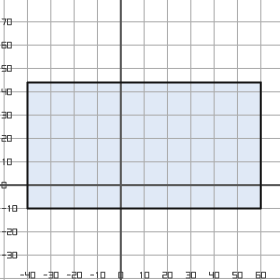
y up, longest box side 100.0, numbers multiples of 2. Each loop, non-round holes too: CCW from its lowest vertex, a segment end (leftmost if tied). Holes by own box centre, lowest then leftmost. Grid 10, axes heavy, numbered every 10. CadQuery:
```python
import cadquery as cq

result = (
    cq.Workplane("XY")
    .moveTo(-40.0, -10.0)
    .lineTo(60.0, -10.0)
    .lineTo(60.0, 44.0)
    .lineTo(-40.0, 44.0)
    .close()
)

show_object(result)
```